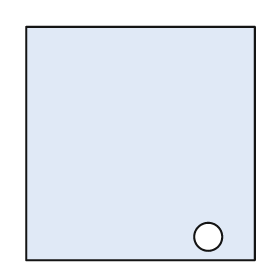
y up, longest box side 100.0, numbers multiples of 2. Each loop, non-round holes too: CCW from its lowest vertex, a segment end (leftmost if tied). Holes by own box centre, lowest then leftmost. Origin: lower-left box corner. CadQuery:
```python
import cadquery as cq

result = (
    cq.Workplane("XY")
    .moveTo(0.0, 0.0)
    .lineTo(98.0, 0.0)
    .lineTo(98.0, 100.0)
    .lineTo(0.0, 100.0)
    .close()
    .moveTo(78.0, 10.0)
    .circle(6.0)
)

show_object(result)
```